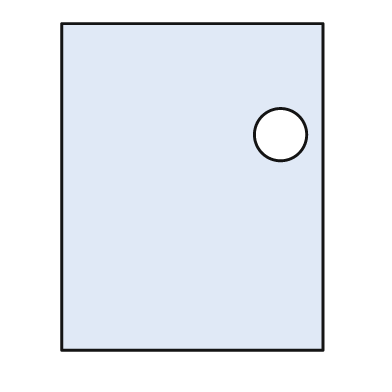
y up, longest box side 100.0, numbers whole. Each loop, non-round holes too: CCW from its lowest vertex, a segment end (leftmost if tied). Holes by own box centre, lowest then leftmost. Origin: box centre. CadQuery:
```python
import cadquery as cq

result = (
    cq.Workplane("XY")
    .moveTo(-40.0, -50.0)
    .lineTo(40.0, -50.0)
    .lineTo(40.0, 50.0)
    .lineTo(-40.0, 50.0)
    .close()
    .moveTo(27.0, 16.0)
    .circle(8.0)
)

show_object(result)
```